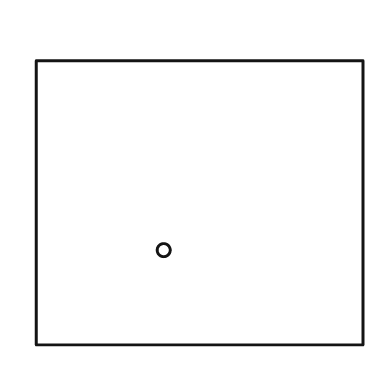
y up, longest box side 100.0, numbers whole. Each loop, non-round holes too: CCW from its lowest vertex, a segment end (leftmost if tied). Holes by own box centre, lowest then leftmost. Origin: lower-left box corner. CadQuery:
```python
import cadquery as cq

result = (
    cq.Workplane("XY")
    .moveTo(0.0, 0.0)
    .lineTo(100.0, 0.0)
    .lineTo(100.0, 87.0)
    .lineTo(0.0, 87.0)
    .close()
    .moveTo(39.0, 29.0)
    .circle(2.0)
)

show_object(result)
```